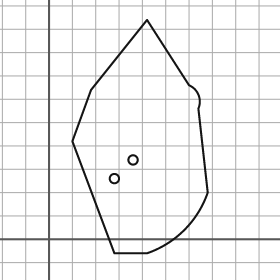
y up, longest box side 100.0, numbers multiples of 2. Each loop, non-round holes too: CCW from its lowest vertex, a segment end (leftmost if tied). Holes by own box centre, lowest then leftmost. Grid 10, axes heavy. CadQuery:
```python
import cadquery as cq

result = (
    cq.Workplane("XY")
    .moveTo(28.0, -6.0)
    .lineTo(42.0, -6.0)
    .threePointArc((58.0, 4.0), (68.0, 20.0))
    .lineTo(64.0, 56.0)
    .threePointArc((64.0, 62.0), (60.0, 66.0))
    .lineTo(42.0, 94.0)
    .lineTo(18.0, 64.0)
    .lineTo(10.0, 42.0)
    .close()
    .moveTo(28.0, 26.0)
    .circle(2.0)
    .moveTo(36.0, 34.0)
    .circle(2.0)
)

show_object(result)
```